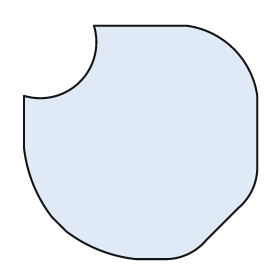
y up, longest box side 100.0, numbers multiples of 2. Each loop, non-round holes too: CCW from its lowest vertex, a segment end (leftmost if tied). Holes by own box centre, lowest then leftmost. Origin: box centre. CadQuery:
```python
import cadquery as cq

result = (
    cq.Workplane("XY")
    .moveTo(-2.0, -50.0)
    .lineTo(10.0, -50.0)
    .threePointArc((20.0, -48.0), (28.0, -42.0))
    .lineTo(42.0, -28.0)
    .threePointArc((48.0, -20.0), (50.0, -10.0))
    .lineTo(50.0, 20.0)
    .threePointArc((40.0, 40.0), (20.0, 50.0))
    .lineTo(-20.0, 50.0)
    .threePointArc((-26.0, 26.0), (-50.0, 20.0))
    .lineTo(-50.0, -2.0)
    .threePointArc((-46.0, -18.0), (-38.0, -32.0))
    .lineTo(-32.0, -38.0)
    .threePointArc((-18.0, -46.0), (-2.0, -50.0))
    .close()
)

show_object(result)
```